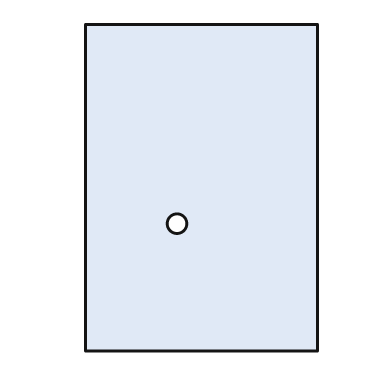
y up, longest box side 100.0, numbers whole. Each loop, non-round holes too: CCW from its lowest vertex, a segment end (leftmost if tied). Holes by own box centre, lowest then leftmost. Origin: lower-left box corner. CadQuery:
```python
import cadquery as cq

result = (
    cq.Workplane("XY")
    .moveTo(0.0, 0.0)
    .lineTo(71.0, 0.0)
    .lineTo(71.0, 100.0)
    .lineTo(0.0, 100.0)
    .close()
    .moveTo(28.0, 39.0)
    .circle(3.0)
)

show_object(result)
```